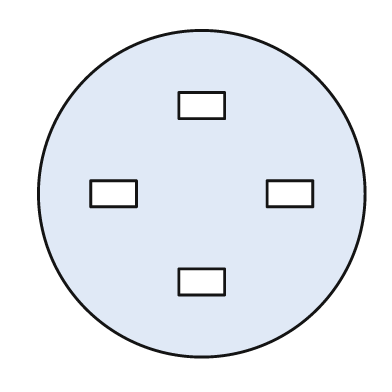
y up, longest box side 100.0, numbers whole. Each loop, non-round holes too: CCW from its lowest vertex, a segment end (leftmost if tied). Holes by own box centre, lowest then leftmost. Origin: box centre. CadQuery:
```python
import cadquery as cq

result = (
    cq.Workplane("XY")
    .moveTo(0.0, 0.0)
    .circle(50.0)
    .moveTo(-7.0, -31.0)
    .lineTo(7.0, -31.0)
    .lineTo(7.0, -23.0)
    .lineTo(-7.0, -23.0)
    .close()
    .moveTo(-34.0, -4.0)
    .lineTo(-20.0, -4.0)
    .lineTo(-20.0, 4.0)
    .lineTo(-34.0, 4.0)
    .close()
    .moveTo(20.0, -4.0)
    .lineTo(34.0, -4.0)
    .lineTo(34.0, 4.0)
    .lineTo(20.0, 4.0)
    .close()
    .moveTo(-7.0, 23.0)
    .lineTo(7.0, 23.0)
    .lineTo(7.0, 31.0)
    .lineTo(-7.0, 31.0)
    .close()
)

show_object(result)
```